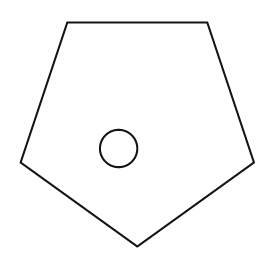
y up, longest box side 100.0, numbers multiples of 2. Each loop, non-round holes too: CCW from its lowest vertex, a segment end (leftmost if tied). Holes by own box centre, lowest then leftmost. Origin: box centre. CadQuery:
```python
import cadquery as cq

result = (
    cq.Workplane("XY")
    .moveTo(0.0, -48.0)
    .lineTo(50.0, -12.0)
    .lineTo(30.0, 48.0)
    .lineTo(-30.0, 48.0)
    .lineTo(-50.0, -12.0)
    .close()
    .moveTo(-8.0, -6.0)
    .circle(8.0)
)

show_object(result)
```